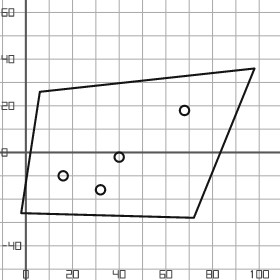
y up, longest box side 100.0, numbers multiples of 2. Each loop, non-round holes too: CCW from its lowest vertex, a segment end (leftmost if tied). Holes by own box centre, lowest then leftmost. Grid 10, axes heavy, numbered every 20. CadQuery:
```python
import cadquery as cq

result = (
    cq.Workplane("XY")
    .moveTo(72.0, -28.0)
    .lineTo(98.0, 36.0)
    .lineTo(6.0, 26.0)
    .lineTo(-2.0, -26.0)
    .close()
    .moveTo(32.0, -16.0)
    .circle(2.0)
    .moveTo(16.0, -10.0)
    .circle(2.0)
    .moveTo(40.0, -2.0)
    .circle(2.0)
    .moveTo(68.0, 18.0)
    .circle(2.0)
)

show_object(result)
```